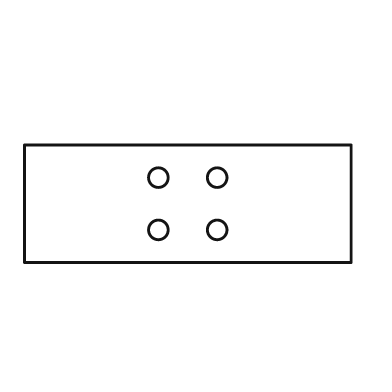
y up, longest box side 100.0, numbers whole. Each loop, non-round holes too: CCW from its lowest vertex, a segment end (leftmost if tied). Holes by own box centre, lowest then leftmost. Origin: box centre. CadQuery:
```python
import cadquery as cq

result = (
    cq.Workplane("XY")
    .moveTo(-50.0, -18.0)
    .lineTo(50.0, -18.0)
    .lineTo(50.0, 18.0)
    .lineTo(-50.0, 18.0)
    .close()
    .moveTo(-9.0, -8.0)
    .circle(3.0)
    .moveTo(9.0, -8.0)
    .circle(3.0)
    .moveTo(-9.0, 8.0)
    .circle(3.0)
    .moveTo(9.0, 8.0)
    .circle(3.0)
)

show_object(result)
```